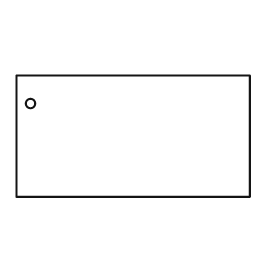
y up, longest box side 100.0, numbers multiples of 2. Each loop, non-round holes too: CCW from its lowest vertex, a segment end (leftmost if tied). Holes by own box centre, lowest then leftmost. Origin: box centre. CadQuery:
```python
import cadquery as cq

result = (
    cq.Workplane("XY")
    .moveTo(-50.0, -26.0)
    .lineTo(50.0, -26.0)
    .lineTo(50.0, 26.0)
    .lineTo(-50.0, 26.0)
    .close()
    .moveTo(-44.0, 14.0)
    .circle(2.0)
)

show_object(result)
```